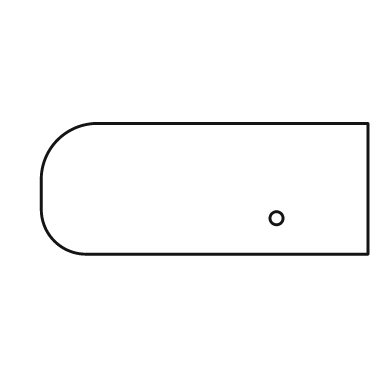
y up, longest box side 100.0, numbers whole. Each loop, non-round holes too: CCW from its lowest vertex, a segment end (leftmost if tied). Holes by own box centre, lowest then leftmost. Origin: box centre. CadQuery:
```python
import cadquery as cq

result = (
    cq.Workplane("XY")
    .moveTo(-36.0, -20.0)
    .lineTo(50.0, -20.0)
    .lineTo(50.0, 20.0)
    .lineTo(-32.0, 20.0)
    .threePointArc((-45.0, 15.0), (-50.0, 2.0))
    .lineTo(-50.0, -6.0)
    .threePointArc((-46.0, -16.0), (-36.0, -20.0))
    .close()
    .moveTo(22.0, -9.0)
    .circle(2.0)
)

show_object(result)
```